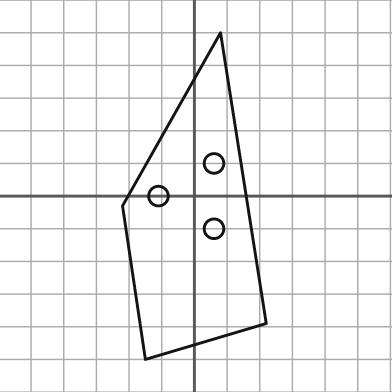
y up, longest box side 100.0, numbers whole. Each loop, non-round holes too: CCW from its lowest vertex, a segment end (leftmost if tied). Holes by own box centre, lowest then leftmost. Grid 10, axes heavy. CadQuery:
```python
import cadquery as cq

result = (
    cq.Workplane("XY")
    .moveTo(-15.0, -50.0)
    .lineTo(22.0, -39.0)
    .lineTo(8.0, 50.0)
    .lineTo(-22.0, -3.0)
    .close()
    .moveTo(6.0, -10.0)
    .circle(3.0)
    .moveTo(-11.0, 0.0)
    .circle(3.0)
    .moveTo(6.0, 10.0)
    .circle(3.0)
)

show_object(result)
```